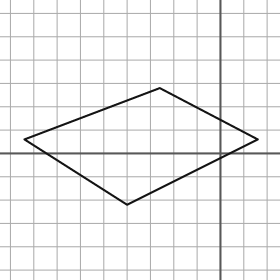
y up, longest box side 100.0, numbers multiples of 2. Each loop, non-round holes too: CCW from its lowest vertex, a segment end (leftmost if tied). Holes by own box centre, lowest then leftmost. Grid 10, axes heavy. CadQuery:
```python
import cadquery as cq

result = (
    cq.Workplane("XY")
    .moveTo(-40.0, -22.0)
    .lineTo(16.0, 6.0)
    .lineTo(-26.0, 28.0)
    .lineTo(-84.0, 6.0)
    .close()
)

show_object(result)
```